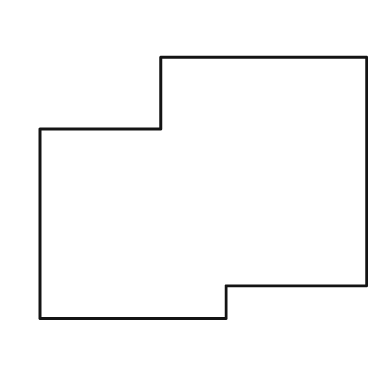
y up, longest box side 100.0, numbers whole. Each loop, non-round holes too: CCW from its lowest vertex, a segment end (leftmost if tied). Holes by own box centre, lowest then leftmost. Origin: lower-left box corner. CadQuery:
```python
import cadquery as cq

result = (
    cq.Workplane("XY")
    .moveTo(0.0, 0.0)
    .lineTo(57.0, 0.0)
    .lineTo(57.0, 10.0)
    .lineTo(100.0, 10.0)
    .lineTo(100.0, 80.0)
    .lineTo(37.0, 80.0)
    .lineTo(37.0, 58.0)
    .lineTo(0.0, 58.0)
    .close()
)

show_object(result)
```